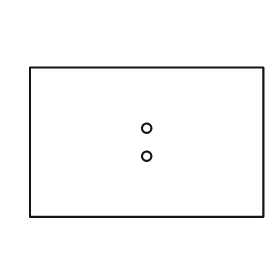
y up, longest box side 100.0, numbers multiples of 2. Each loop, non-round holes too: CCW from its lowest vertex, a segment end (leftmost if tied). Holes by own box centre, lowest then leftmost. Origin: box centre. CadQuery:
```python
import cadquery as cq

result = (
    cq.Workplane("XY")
    .moveTo(-50.0, -32.0)
    .lineTo(50.0, -32.0)
    .lineTo(50.0, 32.0)
    .lineTo(-50.0, 32.0)
    .close()
    .moveTo(0.0, -6.0)
    .circle(2.0)
    .moveTo(0.0, 6.0)
    .circle(2.0)
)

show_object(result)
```